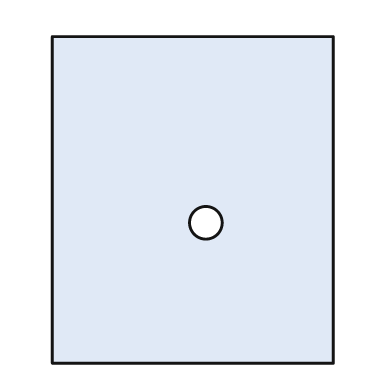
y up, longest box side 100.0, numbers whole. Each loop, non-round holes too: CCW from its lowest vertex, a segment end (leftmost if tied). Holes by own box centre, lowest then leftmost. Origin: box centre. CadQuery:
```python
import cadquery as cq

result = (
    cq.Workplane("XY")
    .moveTo(-43.0, -50.0)
    .lineTo(43.0, -50.0)
    .lineTo(43.0, 50.0)
    .lineTo(-43.0, 50.0)
    .close()
    .moveTo(4.0, -7.0)
    .circle(5.0)
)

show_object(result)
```